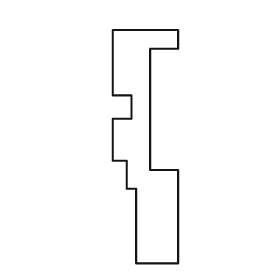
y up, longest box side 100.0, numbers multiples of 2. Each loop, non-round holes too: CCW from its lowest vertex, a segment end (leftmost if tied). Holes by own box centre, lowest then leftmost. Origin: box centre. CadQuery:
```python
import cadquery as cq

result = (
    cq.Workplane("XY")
    .moveTo(-4.0, -50.0)
    .lineTo(14.0, -50.0)
    .lineTo(14.0, -10.0)
    .lineTo(2.0, -10.0)
    .lineTo(2.0, 42.0)
    .lineTo(14.0, 42.0)
    .lineTo(14.0, 50.0)
    .lineTo(-14.0, 50.0)
    .lineTo(-14.0, 22.0)
    .lineTo(-6.0, 22.0)
    .lineTo(-6.0, 12.0)
    .lineTo(-14.0, 12.0)
    .lineTo(-14.0, -6.0)
    .lineTo(-8.0, -6.0)
    .lineTo(-8.0, -18.0)
    .lineTo(-4.0, -18.0)
    .close()
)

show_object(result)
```